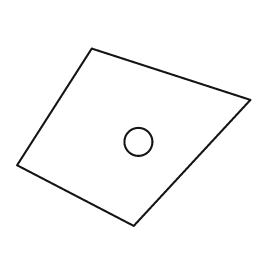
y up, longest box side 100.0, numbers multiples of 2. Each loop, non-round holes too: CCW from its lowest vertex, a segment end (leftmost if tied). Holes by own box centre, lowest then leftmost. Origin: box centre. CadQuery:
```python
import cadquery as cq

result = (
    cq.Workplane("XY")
    .moveTo(0.0, -38.0)
    .lineTo(50.0, 16.0)
    .lineTo(-18.0, 38.0)
    .lineTo(-50.0, -12.0)
    .close()
    .moveTo(2.0, -2.0)
    .circle(6.0)
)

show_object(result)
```